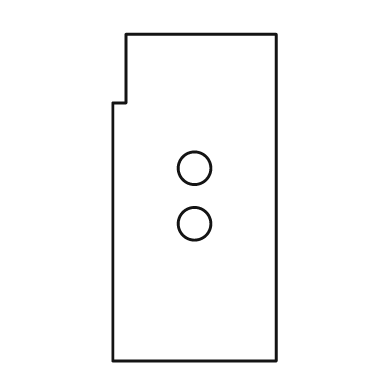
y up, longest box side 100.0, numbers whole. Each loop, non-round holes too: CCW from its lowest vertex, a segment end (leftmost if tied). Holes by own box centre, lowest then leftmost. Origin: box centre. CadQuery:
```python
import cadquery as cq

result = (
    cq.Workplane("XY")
    .moveTo(-25.0, -50.0)
    .lineTo(25.0, -50.0)
    .lineTo(25.0, 50.0)
    .lineTo(-21.0, 50.0)
    .lineTo(-21.0, 29.0)
    .lineTo(-25.0, 29.0)
    .close()
    .moveTo(0.0, -8.0)
    .circle(5.0)
    .moveTo(0.0, 9.0)
    .circle(5.0)
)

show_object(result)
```